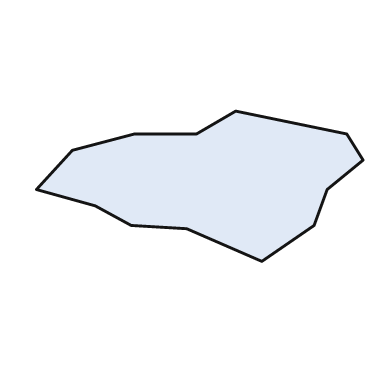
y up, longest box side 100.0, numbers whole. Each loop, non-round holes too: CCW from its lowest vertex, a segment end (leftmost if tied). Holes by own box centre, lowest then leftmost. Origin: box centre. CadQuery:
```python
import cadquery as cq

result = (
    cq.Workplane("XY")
    .moveTo(19.0, -23.0)
    .lineTo(35.0, -12.0)
    .lineTo(39.0, -1.0)
    .lineTo(50.0, 8.0)
    .lineTo(45.0, 16.0)
    .lineTo(11.0, 23.0)
    .lineTo(-1.0, 16.0)
    .lineTo(-20.0, 16.0)
    .lineTo(-39.0, 11.0)
    .lineTo(-50.0, -1.0)
    .lineTo(-32.0, -6.0)
    .lineTo(-21.0, -12.0)
    .lineTo(-4.0, -13.0)
    .close()
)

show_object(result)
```